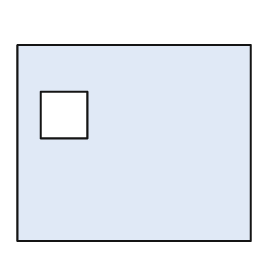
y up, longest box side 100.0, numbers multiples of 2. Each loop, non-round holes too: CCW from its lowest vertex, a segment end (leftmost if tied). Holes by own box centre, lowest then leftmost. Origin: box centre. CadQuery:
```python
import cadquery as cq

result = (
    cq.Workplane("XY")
    .moveTo(-50.0, -42.0)
    .lineTo(50.0, -42.0)
    .lineTo(50.0, 42.0)
    .lineTo(-50.0, 42.0)
    .close()
    .moveTo(-40.0, 2.0)
    .lineTo(-20.0, 2.0)
    .lineTo(-20.0, 22.0)
    .lineTo(-40.0, 22.0)
    .close()
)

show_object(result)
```